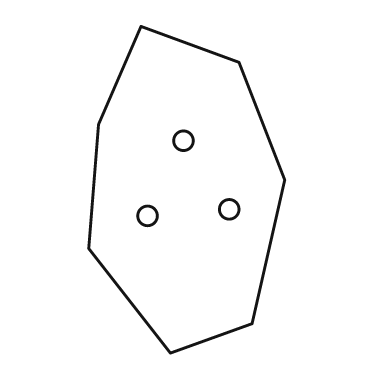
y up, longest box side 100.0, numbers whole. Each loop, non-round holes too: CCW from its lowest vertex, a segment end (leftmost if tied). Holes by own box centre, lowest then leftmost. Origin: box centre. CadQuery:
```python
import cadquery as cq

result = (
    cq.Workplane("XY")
    .moveTo(-5.0, -50.0)
    .lineTo(20.0, -41.0)
    .lineTo(30.0, 3.0)
    .lineTo(16.0, 39.0)
    .lineTo(-14.0, 50.0)
    .lineTo(-27.0, 20.0)
    .lineTo(-30.0, -18.0)
    .close()
    .moveTo(-12.0, -8.0)
    .circle(3.0)
    .moveTo(13.0, -6.0)
    .circle(3.0)
    .moveTo(-1.0, 15.0)
    .circle(3.0)
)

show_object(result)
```